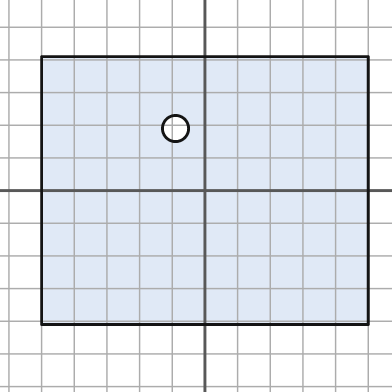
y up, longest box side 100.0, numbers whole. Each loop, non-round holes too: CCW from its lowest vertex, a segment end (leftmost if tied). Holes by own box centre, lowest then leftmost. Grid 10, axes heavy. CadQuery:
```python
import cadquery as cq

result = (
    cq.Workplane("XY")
    .moveTo(-50.0, -41.0)
    .lineTo(50.0, -41.0)
    .lineTo(50.0, 41.0)
    .lineTo(-50.0, 41.0)
    .close()
    .moveTo(-9.0, 19.0)
    .circle(4.0)
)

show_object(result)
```